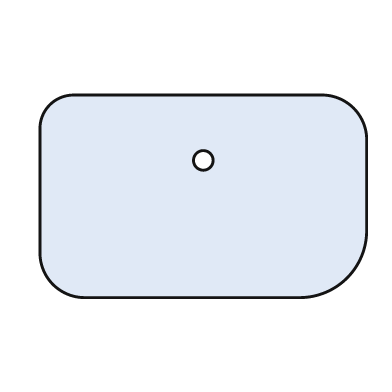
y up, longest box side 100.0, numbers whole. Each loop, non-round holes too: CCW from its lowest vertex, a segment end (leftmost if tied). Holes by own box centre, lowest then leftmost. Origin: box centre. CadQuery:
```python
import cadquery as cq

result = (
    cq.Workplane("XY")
    .moveTo(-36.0, -31.0)
    .lineTo(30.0, -31.0)
    .threePointArc((44.0, -25.0), (50.0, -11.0))
    .lineTo(50.0, 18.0)
    .threePointArc((46.0, 27.0), (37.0, 31.0))
    .lineTo(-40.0, 31.0)
    .threePointArc((-47.0, 28.0), (-50.0, 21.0))
    .lineTo(-50.0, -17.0)
    .threePointArc((-46.0, -27.0), (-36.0, -31.0))
    .close()
    .moveTo(0.0, 11.0)
    .circle(3.0)
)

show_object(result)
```